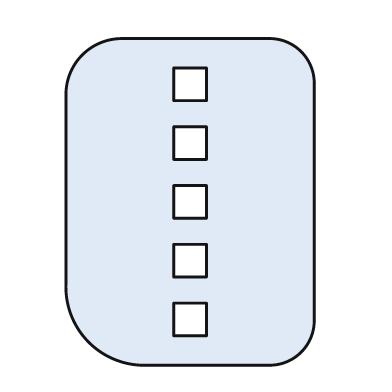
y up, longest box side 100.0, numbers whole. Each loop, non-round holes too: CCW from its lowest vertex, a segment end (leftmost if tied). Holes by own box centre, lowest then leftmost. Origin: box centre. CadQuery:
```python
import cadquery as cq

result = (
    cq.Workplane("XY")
    .moveTo(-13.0, -50.0)
    .lineTo(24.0, -50.0)
    .threePointArc((34.0, -46.0), (38.0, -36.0))
    .lineTo(38.0, 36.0)
    .threePointArc((34.0, 46.0), (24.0, 50.0))
    .lineTo(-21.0, 50.0)
    .threePointArc((-33.0, 45.0), (-38.0, 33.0))
    .lineTo(-38.0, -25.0)
    .threePointArc((-31.0, -43.0), (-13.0, -50.0))
    .close()
    .moveTo(-5.0, -41.0)
    .lineTo(5.0, -41.0)
    .lineTo(5.0, -31.0)
    .lineTo(-5.0, -31.0)
    .close()
    .moveTo(-5.0, -23.0)
    .lineTo(5.0, -23.0)
    .lineTo(5.0, -13.0)
    .lineTo(-5.0, -13.0)
    .close()
    .moveTo(-5.0, -5.0)
    .lineTo(5.0, -5.0)
    .lineTo(5.0, 5.0)
    .lineTo(-5.0, 5.0)
    .close()
    .moveTo(-5.0, 13.0)
    .lineTo(5.0, 13.0)
    .lineTo(5.0, 23.0)
    .lineTo(-5.0, 23.0)
    .close()
    .moveTo(-5.0, 31.0)
    .lineTo(5.0, 31.0)
    .lineTo(5.0, 41.0)
    .lineTo(-5.0, 41.0)
    .close()
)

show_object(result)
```